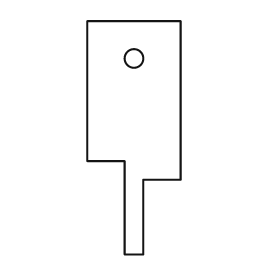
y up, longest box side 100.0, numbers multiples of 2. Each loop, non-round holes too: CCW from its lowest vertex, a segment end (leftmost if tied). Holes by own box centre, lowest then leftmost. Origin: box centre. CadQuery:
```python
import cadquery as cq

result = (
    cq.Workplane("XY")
    .moveTo(-4.0, -50.0)
    .lineTo(4.0, -50.0)
    .lineTo(4.0, -18.0)
    .lineTo(20.0, -18.0)
    .lineTo(20.0, 50.0)
    .lineTo(-20.0, 50.0)
    .lineTo(-20.0, -10.0)
    .lineTo(-4.0, -10.0)
    .close()
    .moveTo(0.0, 34.0)
    .circle(4.0)
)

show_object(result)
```